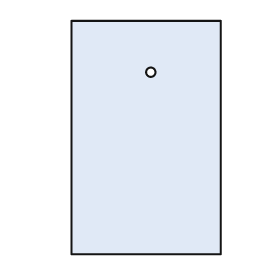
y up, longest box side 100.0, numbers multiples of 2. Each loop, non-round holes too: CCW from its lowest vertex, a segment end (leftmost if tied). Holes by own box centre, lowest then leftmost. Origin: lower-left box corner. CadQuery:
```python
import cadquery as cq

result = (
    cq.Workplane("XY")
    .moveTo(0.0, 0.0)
    .lineTo(64.0, 0.0)
    .lineTo(64.0, 100.0)
    .lineTo(0.0, 100.0)
    .close()
    .moveTo(34.0, 78.0)
    .circle(2.0)
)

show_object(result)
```